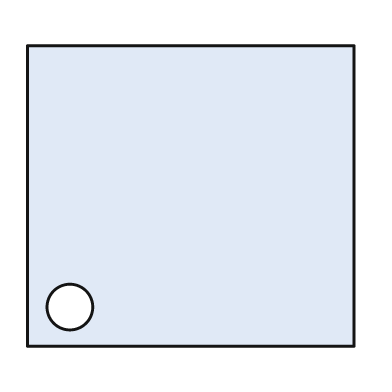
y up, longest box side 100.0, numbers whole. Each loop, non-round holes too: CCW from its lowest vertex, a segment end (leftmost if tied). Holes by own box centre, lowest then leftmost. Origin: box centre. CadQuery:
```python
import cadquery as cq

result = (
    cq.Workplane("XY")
    .moveTo(-50.0, -46.0)
    .lineTo(50.0, -46.0)
    .lineTo(50.0, 46.0)
    .lineTo(-50.0, 46.0)
    .close()
    .moveTo(-37.0, -34.0)
    .circle(7.0)
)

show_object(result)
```